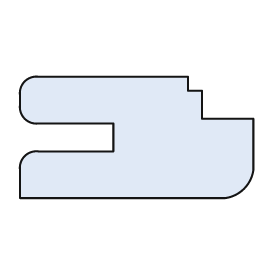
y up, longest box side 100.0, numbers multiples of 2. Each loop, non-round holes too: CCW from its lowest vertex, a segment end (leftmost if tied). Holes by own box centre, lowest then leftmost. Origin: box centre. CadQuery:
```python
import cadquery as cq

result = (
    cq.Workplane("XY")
    .moveTo(-50.0, -26.0)
    .lineTo(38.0, -26.0)
    .threePointArc((46.0, -22.0), (50.0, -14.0))
    .lineTo(50.0, 8.0)
    .lineTo(28.0, 8.0)
    .lineTo(28.0, 20.0)
    .lineTo(22.0, 20.0)
    .lineTo(22.0, 26.0)
    .lineTo(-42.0, 26.0)
    .threePointArc((-48.0, 24.0), (-50.0, 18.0))
    .lineTo(-50.0, 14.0)
    .threePointArc((-48.0, 8.0), (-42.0, 6.0))
    .lineTo(-10.0, 6.0)
    .lineTo(-10.0, -6.0)
    .lineTo(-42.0, -6.0)
    .threePointArc((-48.0, -8.0), (-50.0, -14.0))
    .close()
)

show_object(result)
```